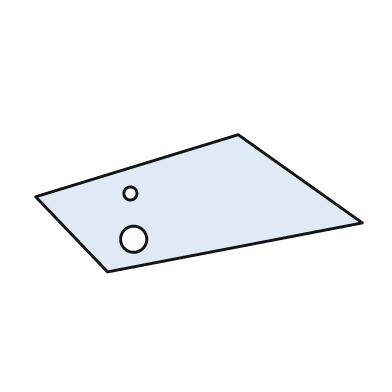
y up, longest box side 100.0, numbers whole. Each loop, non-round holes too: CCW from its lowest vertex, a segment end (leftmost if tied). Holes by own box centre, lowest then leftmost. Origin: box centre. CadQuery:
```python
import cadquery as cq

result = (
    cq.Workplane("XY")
    .moveTo(-28.0, -21.0)
    .lineTo(50.0, -6.0)
    .lineTo(12.0, 21.0)
    .lineTo(-50.0, 2.0)
    .close()
    .moveTo(-20.0, -11.0)
    .circle(4.0)
    .moveTo(-21.0, 3.0)
    .circle(2.0)
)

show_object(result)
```